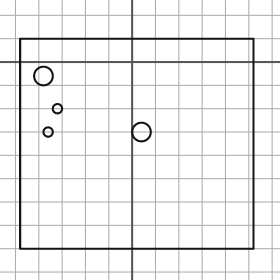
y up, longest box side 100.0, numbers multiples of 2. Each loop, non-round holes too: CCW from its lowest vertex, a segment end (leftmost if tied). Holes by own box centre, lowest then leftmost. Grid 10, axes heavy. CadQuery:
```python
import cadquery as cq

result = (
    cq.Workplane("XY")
    .moveTo(-48.0, -80.0)
    .lineTo(52.0, -80.0)
    .lineTo(52.0, 10.0)
    .lineTo(-48.0, 10.0)
    .close()
    .moveTo(-36.0, -30.0)
    .circle(2.0)
    .moveTo(4.0, -30.0)
    .circle(4.0)
    .moveTo(-32.0, -20.0)
    .circle(2.0)
    .moveTo(-38.0, -6.0)
    .circle(4.0)
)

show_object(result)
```